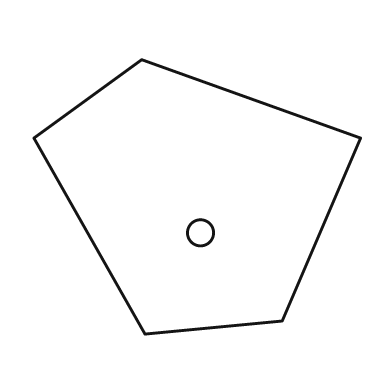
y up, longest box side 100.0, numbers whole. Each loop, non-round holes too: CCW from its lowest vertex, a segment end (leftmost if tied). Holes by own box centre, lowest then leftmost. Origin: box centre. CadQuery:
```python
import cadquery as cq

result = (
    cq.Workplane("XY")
    .moveTo(-16.0, -42.0)
    .lineTo(26.0, -38.0)
    .lineTo(50.0, 18.0)
    .lineTo(-17.0, 42.0)
    .lineTo(-50.0, 18.0)
    .close()
    .moveTo(1.0, -11.0)
    .circle(4.0)
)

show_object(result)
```